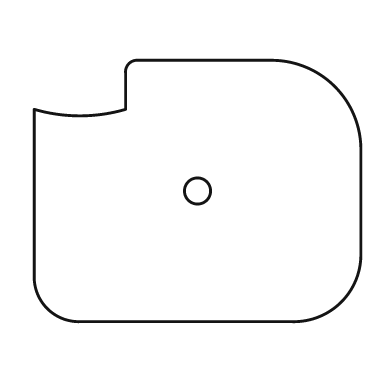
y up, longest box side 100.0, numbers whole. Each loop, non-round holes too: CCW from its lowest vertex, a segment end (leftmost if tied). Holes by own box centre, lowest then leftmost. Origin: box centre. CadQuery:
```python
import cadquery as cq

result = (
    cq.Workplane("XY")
    .moveTo(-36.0, -40.0)
    .lineTo(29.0, -40.0)
    .threePointArc((44.0, -34.0), (50.0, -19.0))
    .lineTo(50.0, 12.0)
    .threePointArc((42.0, 32.0), (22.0, 40.0))
    .lineTo(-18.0, 40.0)
    .threePointArc((-21.0, 39.0), (-22.0, 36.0))
    .lineTo(-22.0, 25.0)
    .threePointArc((-36.0, 23.0), (-50.0, 25.0))
    .lineTo(-50.0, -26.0)
    .threePointArc((-46.0, -36.0), (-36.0, -40.0))
    .close()
    .moveTo(0.0, 0.0)
    .circle(4.0)
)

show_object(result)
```